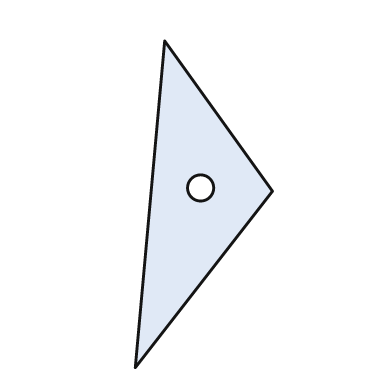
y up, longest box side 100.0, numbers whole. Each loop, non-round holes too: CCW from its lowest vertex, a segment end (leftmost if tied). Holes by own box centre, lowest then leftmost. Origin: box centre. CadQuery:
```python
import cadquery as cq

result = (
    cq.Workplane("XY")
    .moveTo(-21.0, -50.0)
    .lineTo(21.0, 4.0)
    .lineTo(-12.0, 50.0)
    .close()
    .moveTo(-1.0, 5.0)
    .circle(4.0)
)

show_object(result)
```